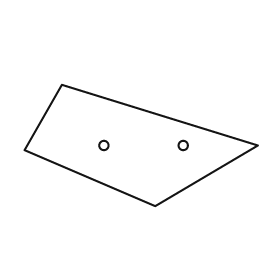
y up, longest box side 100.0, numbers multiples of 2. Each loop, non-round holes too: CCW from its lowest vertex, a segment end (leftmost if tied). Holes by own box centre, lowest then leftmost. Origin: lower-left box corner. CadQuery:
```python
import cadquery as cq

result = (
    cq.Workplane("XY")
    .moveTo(56.0, 0.0)
    .lineTo(100.0, 26.0)
    .lineTo(16.0, 52.0)
    .lineTo(0.0, 24.0)
    .close()
    .moveTo(34.0, 26.0)
    .circle(2.0)
    .moveTo(68.0, 26.0)
    .circle(2.0)
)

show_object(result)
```